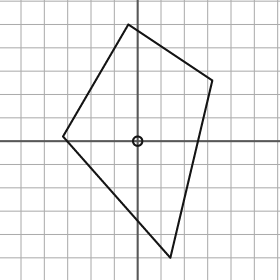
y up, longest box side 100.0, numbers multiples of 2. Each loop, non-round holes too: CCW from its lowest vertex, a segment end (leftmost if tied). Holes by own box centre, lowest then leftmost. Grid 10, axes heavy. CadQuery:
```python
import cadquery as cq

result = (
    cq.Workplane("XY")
    .moveTo(14.0, -50.0)
    .lineTo(32.0, 26.0)
    .lineTo(-4.0, 50.0)
    .lineTo(-32.0, 2.0)
    .close()
    .moveTo(0.0, 0.0)
    .circle(2.0)
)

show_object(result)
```